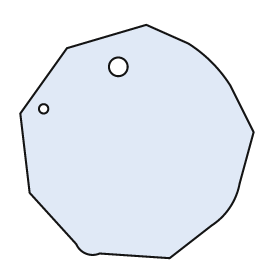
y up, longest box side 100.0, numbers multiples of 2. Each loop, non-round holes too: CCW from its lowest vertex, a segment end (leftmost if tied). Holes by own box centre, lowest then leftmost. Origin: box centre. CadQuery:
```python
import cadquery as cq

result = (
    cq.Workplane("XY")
    .moveTo(14.0, -50.0)
    .lineTo(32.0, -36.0)
    .threePointArc((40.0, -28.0), (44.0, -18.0))
    .lineTo(50.0, 4.0)
    .lineTo(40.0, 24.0)
    .threePointArc((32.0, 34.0), (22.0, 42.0))
    .lineTo(4.0, 50.0)
    .lineTo(-30.0, 40.0)
    .lineTo(-50.0, 12.0)
    .lineTo(-46.0, -22.0)
    .lineTo(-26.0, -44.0)
    .threePointArc((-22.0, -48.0), (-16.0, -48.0))
    .close()
    .moveTo(-40.0, 14.0)
    .circle(2.0)
    .moveTo(-8.0, 32.0)
    .circle(4.0)
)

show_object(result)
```